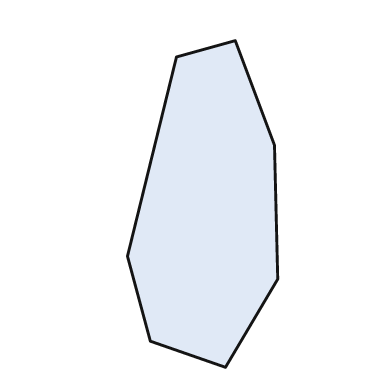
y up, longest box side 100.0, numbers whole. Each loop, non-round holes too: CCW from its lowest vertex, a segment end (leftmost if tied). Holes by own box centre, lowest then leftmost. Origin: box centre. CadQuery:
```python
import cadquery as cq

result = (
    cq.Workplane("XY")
    .moveTo(7.0, -50.0)
    .lineTo(23.0, -23.0)
    .lineTo(22.0, 18.0)
    .lineTo(10.0, 50.0)
    .lineTo(-8.0, 45.0)
    .lineTo(-23.0, -16.0)
    .lineTo(-16.0, -42.0)
    .close()
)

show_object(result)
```